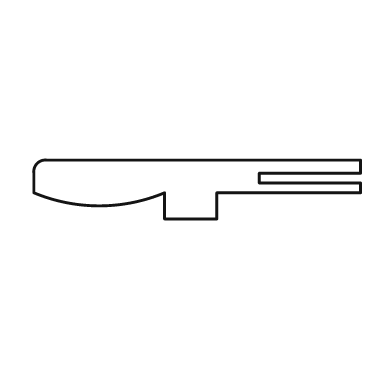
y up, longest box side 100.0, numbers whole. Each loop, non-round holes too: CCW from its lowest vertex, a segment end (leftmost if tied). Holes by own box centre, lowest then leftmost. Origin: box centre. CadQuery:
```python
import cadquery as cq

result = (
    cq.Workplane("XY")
    .moveTo(-10.0, -9.0)
    .lineTo(6.0, -9.0)
    .lineTo(6.0, -1.0)
    .lineTo(50.0, -1.0)
    .lineTo(50.0, 2.0)
    .lineTo(19.0, 2.0)
    .lineTo(19.0, 5.0)
    .lineTo(50.0, 5.0)
    .lineTo(50.0, 9.0)
    .lineTo(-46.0, 9.0)
    .threePointArc((-49.0, 8.0), (-50.0, 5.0))
    .lineTo(-50.0, -1.0)
    .threePointArc((-30.0, -5.0), (-10.0, -1.0))
    .close()
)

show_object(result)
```